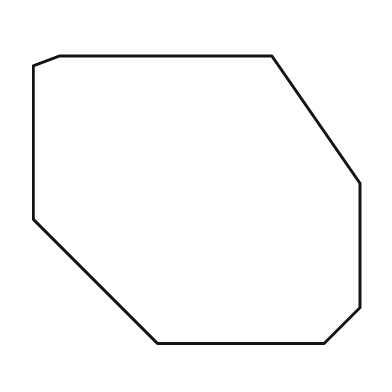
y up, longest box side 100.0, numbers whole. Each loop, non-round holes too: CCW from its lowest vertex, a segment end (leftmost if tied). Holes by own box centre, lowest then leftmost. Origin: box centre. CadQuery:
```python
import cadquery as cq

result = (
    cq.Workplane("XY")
    .moveTo(-12.0, -44.0)
    .lineTo(39.0, -44.0)
    .lineTo(50.0, -33.0)
    .lineTo(50.0, 5.0)
    .lineTo(23.0, 44.0)
    .lineTo(-42.0, 44.0)
    .lineTo(-50.0, 41.0)
    .lineTo(-50.0, -6.0)
    .close()
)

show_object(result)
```